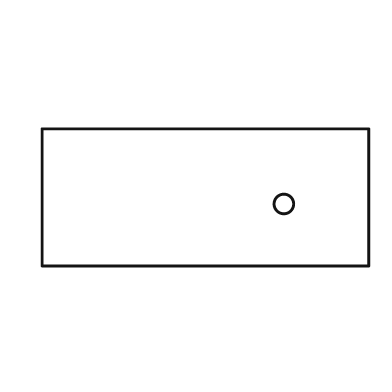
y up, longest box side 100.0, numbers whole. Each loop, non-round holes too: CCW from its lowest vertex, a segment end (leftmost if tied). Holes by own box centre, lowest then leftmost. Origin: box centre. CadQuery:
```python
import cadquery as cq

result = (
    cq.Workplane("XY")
    .moveTo(-50.0, -21.0)
    .lineTo(50.0, -21.0)
    .lineTo(50.0, 21.0)
    .lineTo(-50.0, 21.0)
    .close()
    .moveTo(24.0, -2.0)
    .circle(3.0)
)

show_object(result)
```